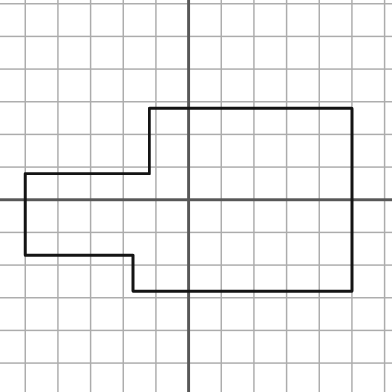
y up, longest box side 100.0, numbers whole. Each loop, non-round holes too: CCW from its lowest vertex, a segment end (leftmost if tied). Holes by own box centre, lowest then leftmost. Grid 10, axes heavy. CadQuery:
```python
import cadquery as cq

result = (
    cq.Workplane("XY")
    .moveTo(-17.0, -28.0)
    .lineTo(50.0, -28.0)
    .lineTo(50.0, 28.0)
    .lineTo(-12.0, 28.0)
    .lineTo(-12.0, 8.0)
    .lineTo(-50.0, 8.0)
    .lineTo(-50.0, -17.0)
    .lineTo(-17.0, -17.0)
    .close()
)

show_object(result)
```